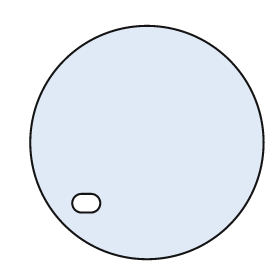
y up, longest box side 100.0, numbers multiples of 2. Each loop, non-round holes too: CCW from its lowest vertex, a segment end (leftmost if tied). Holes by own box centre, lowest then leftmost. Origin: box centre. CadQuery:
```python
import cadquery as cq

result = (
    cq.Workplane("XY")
    .moveTo(0.0, 0.0)
    .circle(50.0)
    .moveTo(-28.0, -30.0)
    .lineTo(-24.0, -30.0)
    .threePointArc((-20.0, -26.0), (-24.0, -22.0))
    .lineTo(-28.0, -22.0)
    .threePointArc((-32.0, -26.0), (-28.0, -30.0))
    .close()
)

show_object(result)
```